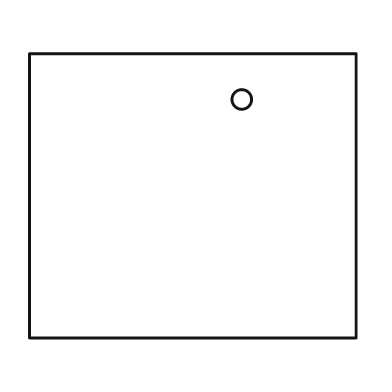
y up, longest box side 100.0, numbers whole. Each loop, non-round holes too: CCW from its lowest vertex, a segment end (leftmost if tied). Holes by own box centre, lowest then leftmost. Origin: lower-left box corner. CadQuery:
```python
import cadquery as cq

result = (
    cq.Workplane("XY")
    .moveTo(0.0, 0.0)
    .lineTo(100.0, 0.0)
    .lineTo(100.0, 87.0)
    .lineTo(0.0, 87.0)
    .close()
    .moveTo(65.0, 73.0)
    .circle(3.0)
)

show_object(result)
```